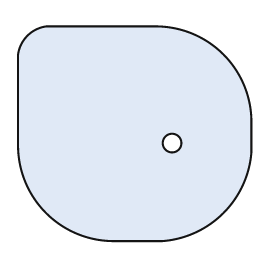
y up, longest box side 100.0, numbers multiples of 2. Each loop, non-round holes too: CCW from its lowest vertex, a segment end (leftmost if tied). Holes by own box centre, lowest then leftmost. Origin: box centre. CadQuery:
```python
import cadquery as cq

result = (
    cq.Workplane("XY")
    .moveTo(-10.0, -46.0)
    .lineTo(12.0, -46.0)
    .threePointArc((38.0, -34.0), (50.0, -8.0))
    .lineTo(50.0, 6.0)
    .threePointArc((38.0, 34.0), (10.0, 46.0))
    .lineTo(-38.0, 46.0)
    .threePointArc((-46.0, 42.0), (-50.0, 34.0))
    .lineTo(-50.0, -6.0)
    .threePointArc((-38.0, -34.0), (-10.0, -46.0))
    .close()
    .moveTo(16.0, -4.0)
    .circle(4.0)
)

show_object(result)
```